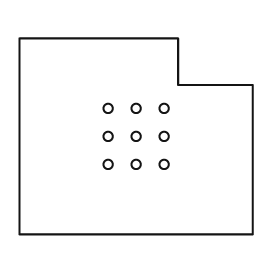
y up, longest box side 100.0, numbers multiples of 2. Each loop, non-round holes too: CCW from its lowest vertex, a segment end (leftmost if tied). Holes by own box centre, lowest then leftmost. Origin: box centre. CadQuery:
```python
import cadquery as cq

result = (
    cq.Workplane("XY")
    .moveTo(-50.0, -42.0)
    .lineTo(50.0, -42.0)
    .lineTo(50.0, 22.0)
    .lineTo(18.0, 22.0)
    .lineTo(18.0, 42.0)
    .lineTo(-50.0, 42.0)
    .close()
    .moveTo(-12.0, -12.0)
    .circle(2.0)
    .moveTo(0.0, -12.0)
    .circle(2.0)
    .moveTo(12.0, -12.0)
    .circle(2.0)
    .moveTo(-12.0, 0.0)
    .circle(2.0)
    .moveTo(0.0, 0.0)
    .circle(2.0)
    .moveTo(12.0, 0.0)
    .circle(2.0)
    .moveTo(-12.0, 12.0)
    .circle(2.0)
    .moveTo(0.0, 12.0)
    .circle(2.0)
    .moveTo(12.0, 12.0)
    .circle(2.0)
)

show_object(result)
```